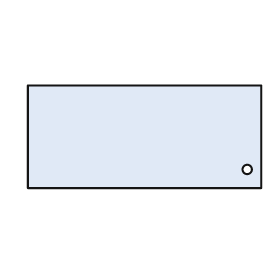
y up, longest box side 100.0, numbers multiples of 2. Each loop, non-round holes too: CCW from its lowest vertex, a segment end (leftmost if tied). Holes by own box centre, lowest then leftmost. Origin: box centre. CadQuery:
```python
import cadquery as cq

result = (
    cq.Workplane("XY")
    .moveTo(-50.0, -22.0)
    .lineTo(50.0, -22.0)
    .lineTo(50.0, 22.0)
    .lineTo(-50.0, 22.0)
    .close()
    .moveTo(44.0, -14.0)
    .circle(2.0)
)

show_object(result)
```